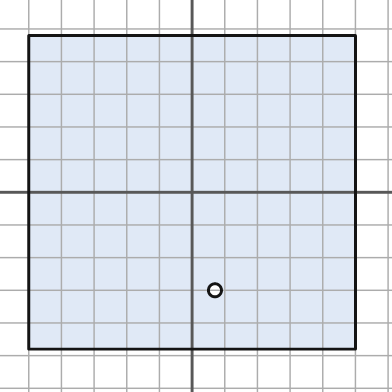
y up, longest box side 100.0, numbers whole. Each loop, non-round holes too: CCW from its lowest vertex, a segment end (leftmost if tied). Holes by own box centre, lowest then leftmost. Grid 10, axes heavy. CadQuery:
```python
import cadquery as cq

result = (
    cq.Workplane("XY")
    .moveTo(-50.0, -48.0)
    .lineTo(50.0, -48.0)
    .lineTo(50.0, 48.0)
    .lineTo(-50.0, 48.0)
    .close()
    .moveTo(7.0, -30.0)
    .circle(2.0)
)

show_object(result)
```